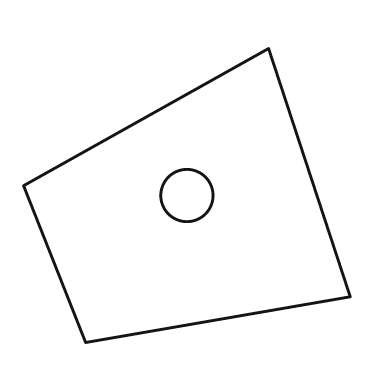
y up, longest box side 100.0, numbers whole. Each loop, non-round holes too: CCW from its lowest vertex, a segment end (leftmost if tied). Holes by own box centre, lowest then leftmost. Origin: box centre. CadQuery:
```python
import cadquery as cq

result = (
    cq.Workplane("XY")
    .moveTo(-31.0, -45.0)
    .lineTo(50.0, -31.0)
    .lineTo(25.0, 45.0)
    .lineTo(-50.0, 3.0)
    .close()
    .moveTo(0.0, 0.0)
    .circle(8.0)
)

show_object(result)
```